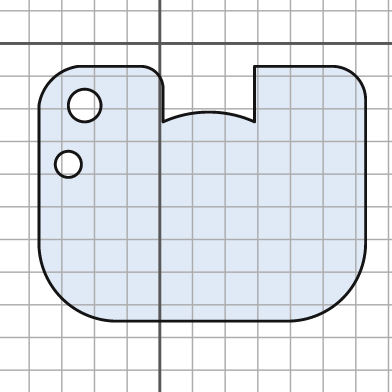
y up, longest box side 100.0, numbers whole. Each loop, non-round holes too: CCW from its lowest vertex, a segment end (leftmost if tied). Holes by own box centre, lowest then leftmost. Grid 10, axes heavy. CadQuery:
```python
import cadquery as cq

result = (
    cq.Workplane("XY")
    .moveTo(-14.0, -85.0)
    .lineTo(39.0, -85.0)
    .threePointArc((56.0, -78.0), (63.0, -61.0))
    .lineTo(63.0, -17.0)
    .threePointArc((60.0, -10.0), (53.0, -7.0))
    .lineTo(29.0, -7.0)
    .lineTo(29.0, -24.0)
    .threePointArc((15.0, -21.0), (1.0, -24.0))
    .lineTo(1.0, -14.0)
    .threePointArc((-1.0, -9.0), (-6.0, -7.0))
    .lineTo(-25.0, -7.0)
    .threePointArc((-33.0, -11.0), (-37.0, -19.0))
    .lineTo(-37.0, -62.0)
    .threePointArc((-30.0, -78.0), (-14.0, -85.0))
    .close()
    .moveTo(-28.0, -37.0)
    .circle(4.0)
    .moveTo(-23.0, -19.0)
    .circle(5.0)
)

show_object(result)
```